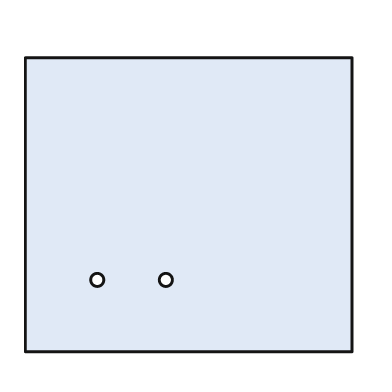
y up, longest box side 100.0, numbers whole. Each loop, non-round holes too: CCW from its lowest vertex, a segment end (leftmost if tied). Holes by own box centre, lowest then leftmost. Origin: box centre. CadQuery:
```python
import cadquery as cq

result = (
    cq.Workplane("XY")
    .moveTo(-50.0, -45.0)
    .lineTo(50.0, -45.0)
    .lineTo(50.0, 45.0)
    .lineTo(-50.0, 45.0)
    .close()
    .moveTo(-28.0, -23.0)
    .circle(2.0)
    .moveTo(-7.0, -23.0)
    .circle(2.0)
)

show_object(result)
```